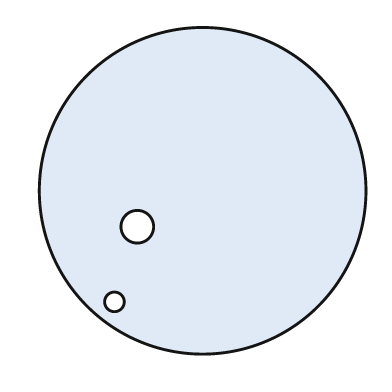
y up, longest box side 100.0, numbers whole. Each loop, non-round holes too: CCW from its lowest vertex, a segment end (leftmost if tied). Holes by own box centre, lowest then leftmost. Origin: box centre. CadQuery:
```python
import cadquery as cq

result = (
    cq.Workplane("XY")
    .moveTo(0.0, 0.0)
    .circle(50.0)
    .moveTo(-27.0, -34.0)
    .circle(3.0)
    .moveTo(-20.0, -11.0)
    .circle(5.0)
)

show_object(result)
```